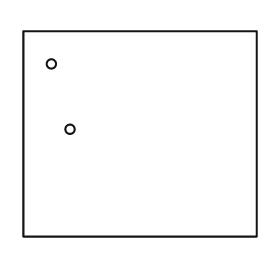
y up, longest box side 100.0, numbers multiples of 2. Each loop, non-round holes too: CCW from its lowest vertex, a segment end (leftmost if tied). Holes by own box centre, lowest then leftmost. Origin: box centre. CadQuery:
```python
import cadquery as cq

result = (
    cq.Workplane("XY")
    .moveTo(-50.0, -44.0)
    .lineTo(50.0, -44.0)
    .lineTo(50.0, 44.0)
    .lineTo(-50.0, 44.0)
    .close()
    .moveTo(-30.0, 2.0)
    .circle(2.0)
    .moveTo(-38.0, 30.0)
    .circle(2.0)
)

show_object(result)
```